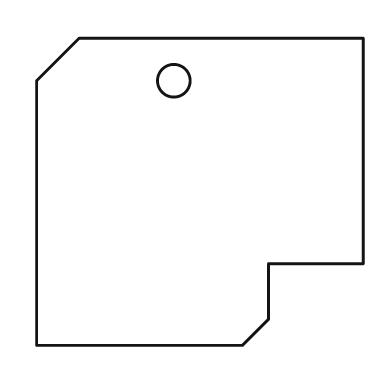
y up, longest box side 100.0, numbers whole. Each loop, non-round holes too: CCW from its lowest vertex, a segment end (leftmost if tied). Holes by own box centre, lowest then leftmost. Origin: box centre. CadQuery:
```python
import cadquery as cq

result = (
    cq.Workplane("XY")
    .moveTo(-50.0, -47.0)
    .lineTo(13.0, -47.0)
    .lineTo(21.0, -39.0)
    .lineTo(21.0, -22.0)
    .lineTo(50.0, -22.0)
    .lineTo(50.0, 47.0)
    .lineTo(-37.0, 47.0)
    .lineTo(-50.0, 34.0)
    .close()
    .moveTo(-8.0, 34.0)
    .circle(5.0)
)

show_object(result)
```